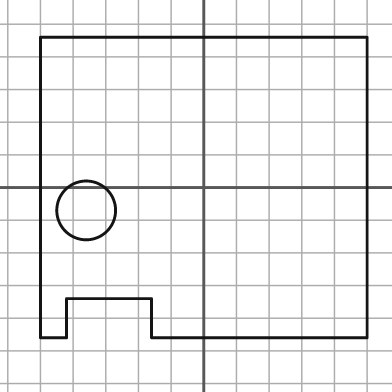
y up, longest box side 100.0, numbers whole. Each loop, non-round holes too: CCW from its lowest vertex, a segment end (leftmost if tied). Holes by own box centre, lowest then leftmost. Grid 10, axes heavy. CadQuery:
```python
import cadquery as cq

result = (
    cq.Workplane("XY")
    .moveTo(-50.0, -46.0)
    .lineTo(-42.0, -46.0)
    .lineTo(-42.0, -34.0)
    .lineTo(-16.0, -34.0)
    .lineTo(-16.0, -46.0)
    .lineTo(50.0, -46.0)
    .lineTo(50.0, 46.0)
    .lineTo(-50.0, 46.0)
    .close()
    .moveTo(-36.0, -7.0)
    .circle(9.0)
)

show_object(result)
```